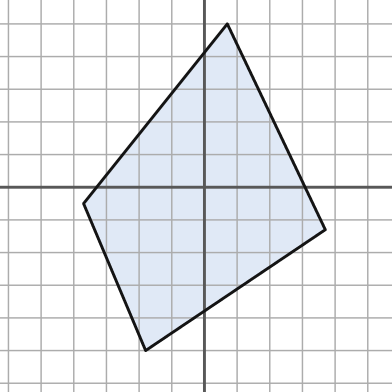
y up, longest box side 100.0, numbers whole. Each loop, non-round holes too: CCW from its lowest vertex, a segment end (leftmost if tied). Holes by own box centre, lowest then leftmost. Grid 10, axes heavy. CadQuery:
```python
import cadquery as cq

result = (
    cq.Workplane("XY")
    .moveTo(-18.0, -50.0)
    .lineTo(37.0, -13.0)
    .lineTo(7.0, 50.0)
    .lineTo(-37.0, -5.0)
    .close()
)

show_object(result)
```